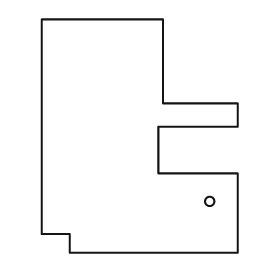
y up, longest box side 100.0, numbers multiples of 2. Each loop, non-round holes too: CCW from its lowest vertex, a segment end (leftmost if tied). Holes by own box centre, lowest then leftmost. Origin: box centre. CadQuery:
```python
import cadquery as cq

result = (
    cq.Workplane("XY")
    .moveTo(-30.0, -50.0)
    .lineTo(42.0, -50.0)
    .lineTo(42.0, -16.0)
    .lineTo(8.0, -16.0)
    .lineTo(8.0, 4.0)
    .lineTo(42.0, 4.0)
    .lineTo(42.0, 14.0)
    .lineTo(10.0, 14.0)
    .lineTo(10.0, 50.0)
    .lineTo(-42.0, 50.0)
    .lineTo(-42.0, -42.0)
    .lineTo(-30.0, -42.0)
    .close()
    .moveTo(30.0, -28.0)
    .circle(2.0)
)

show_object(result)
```